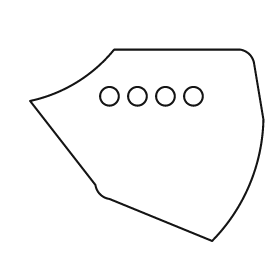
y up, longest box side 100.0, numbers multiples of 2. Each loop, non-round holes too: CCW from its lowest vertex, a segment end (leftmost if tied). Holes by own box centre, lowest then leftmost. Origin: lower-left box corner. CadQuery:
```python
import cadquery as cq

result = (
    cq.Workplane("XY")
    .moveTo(78.0, 0.0)
    .threePointArc((94.0, 24.0), (100.0, 52.0))
    .lineTo(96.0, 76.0)
    .threePointArc((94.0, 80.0), (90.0, 82.0))
    .lineTo(36.0, 82.0)
    .threePointArc((20.0, 68.0), (0.0, 60.0))
    .lineTo(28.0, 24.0)
    .threePointArc((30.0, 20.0), (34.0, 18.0))
    .close()
    .moveTo(34.0, 62.0)
    .circle(4.0)
    .moveTo(46.0, 62.0)
    .circle(4.0)
    .moveTo(58.0, 62.0)
    .circle(4.0)
    .moveTo(70.0, 62.0)
    .circle(4.0)
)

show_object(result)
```